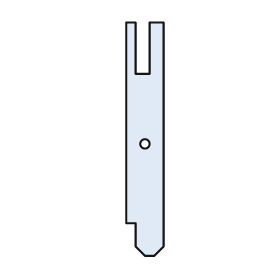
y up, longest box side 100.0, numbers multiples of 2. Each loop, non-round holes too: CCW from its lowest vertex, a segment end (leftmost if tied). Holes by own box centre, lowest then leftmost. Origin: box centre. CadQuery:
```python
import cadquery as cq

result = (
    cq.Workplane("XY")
    .moveTo(0.0, -50.0)
    .lineTo(4.0, -50.0)
    .lineTo(8.0, -46.0)
    .lineTo(8.0, 50.0)
    .lineTo(2.0, 50.0)
    .lineTo(2.0, 28.0)
    .lineTo(-4.0, 28.0)
    .lineTo(-4.0, 50.0)
    .lineTo(-8.0, 50.0)
    .lineTo(-8.0, -36.0)
    .lineTo(-4.0, -36.0)
    .lineTo(-4.0, -46.0)
    .close()
    .moveTo(0.0, -2.0)
    .circle(2.0)
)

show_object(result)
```